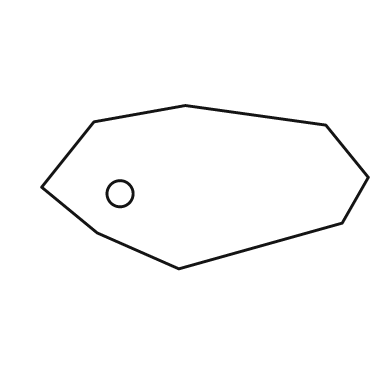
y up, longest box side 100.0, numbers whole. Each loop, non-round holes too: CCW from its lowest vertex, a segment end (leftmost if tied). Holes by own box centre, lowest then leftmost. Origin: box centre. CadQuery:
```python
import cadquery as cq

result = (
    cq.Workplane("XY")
    .moveTo(-8.0, -25.0)
    .lineTo(42.0, -11.0)
    .lineTo(50.0, 3.0)
    .lineTo(37.0, 19.0)
    .lineTo(-6.0, 25.0)
    .lineTo(-34.0, 20.0)
    .lineTo(-50.0, 0.0)
    .lineTo(-33.0, -14.0)
    .close()
    .moveTo(-26.0, -2.0)
    .circle(4.0)
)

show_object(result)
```